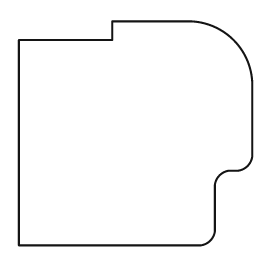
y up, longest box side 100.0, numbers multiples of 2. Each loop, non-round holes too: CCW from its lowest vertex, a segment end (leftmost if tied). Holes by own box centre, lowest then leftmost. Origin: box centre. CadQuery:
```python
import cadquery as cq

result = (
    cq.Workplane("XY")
    .moveTo(-50.0, -48.0)
    .lineTo(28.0, -48.0)
    .threePointArc((32.0, -46.0), (34.0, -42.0))
    .lineTo(34.0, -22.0)
    .threePointArc((36.0, -18.0), (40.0, -16.0))
    .lineTo(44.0, -16.0)
    .threePointArc((48.0, -14.0), (50.0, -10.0))
    .lineTo(50.0, 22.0)
    .threePointArc((42.0, 40.0), (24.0, 48.0))
    .lineTo(-10.0, 48.0)
    .lineTo(-10.0, 40.0)
    .lineTo(-50.0, 40.0)
    .close()
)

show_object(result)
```